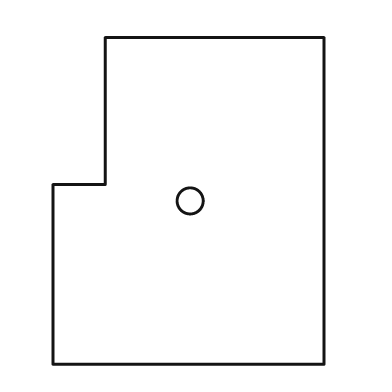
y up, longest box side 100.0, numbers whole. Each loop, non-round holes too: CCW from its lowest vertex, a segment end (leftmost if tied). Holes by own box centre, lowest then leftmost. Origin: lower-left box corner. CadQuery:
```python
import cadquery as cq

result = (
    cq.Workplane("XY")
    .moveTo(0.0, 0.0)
    .lineTo(83.0, 0.0)
    .lineTo(83.0, 100.0)
    .lineTo(16.0, 100.0)
    .lineTo(16.0, 55.0)
    .lineTo(0.0, 55.0)
    .close()
    .moveTo(42.0, 50.0)
    .circle(4.0)
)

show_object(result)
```